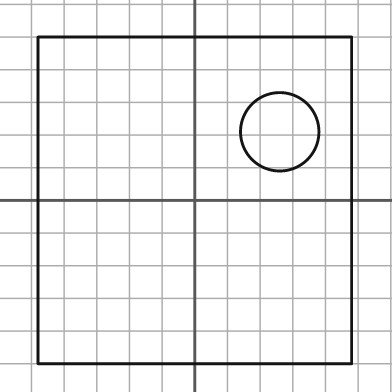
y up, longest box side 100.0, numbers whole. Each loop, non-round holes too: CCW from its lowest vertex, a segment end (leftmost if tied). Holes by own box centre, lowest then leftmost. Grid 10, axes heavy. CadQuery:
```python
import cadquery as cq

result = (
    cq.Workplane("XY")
    .moveTo(-48.0, -50.0)
    .lineTo(48.0, -50.0)
    .lineTo(48.0, 50.0)
    .lineTo(-48.0, 50.0)
    .close()
    .moveTo(26.0, 21.0)
    .circle(12.0)
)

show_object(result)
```